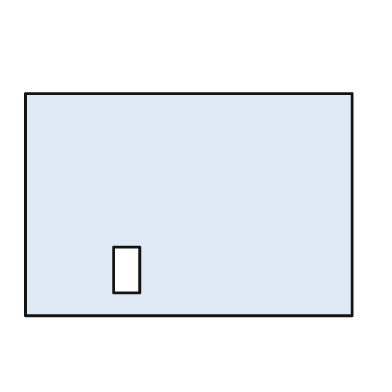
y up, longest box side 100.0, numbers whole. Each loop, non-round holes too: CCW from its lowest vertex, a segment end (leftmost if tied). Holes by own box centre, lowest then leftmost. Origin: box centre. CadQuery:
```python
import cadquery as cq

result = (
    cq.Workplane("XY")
    .moveTo(-50.0, -34.0)
    .lineTo(50.0, -34.0)
    .lineTo(50.0, 34.0)
    .lineTo(-50.0, 34.0)
    .close()
    .moveTo(-23.0, -27.0)
    .lineTo(-15.0, -27.0)
    .lineTo(-15.0, -13.0)
    .lineTo(-23.0, -13.0)
    .close()
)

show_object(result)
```